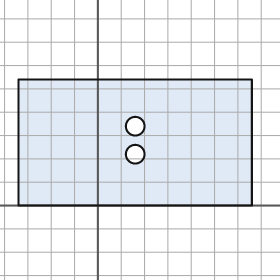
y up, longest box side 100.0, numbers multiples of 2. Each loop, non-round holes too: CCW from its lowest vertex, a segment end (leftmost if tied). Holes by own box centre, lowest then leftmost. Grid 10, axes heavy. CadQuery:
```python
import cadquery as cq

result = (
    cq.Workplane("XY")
    .moveTo(-34.0, 0.0)
    .lineTo(66.0, 0.0)
    .lineTo(66.0, 54.0)
    .lineTo(-34.0, 54.0)
    .close()
    .moveTo(16.0, 22.0)
    .circle(4.0)
    .moveTo(16.0, 34.0)
    .circle(4.0)
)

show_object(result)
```